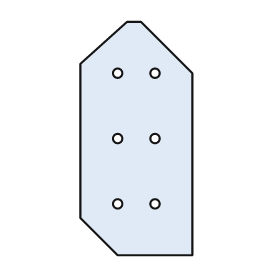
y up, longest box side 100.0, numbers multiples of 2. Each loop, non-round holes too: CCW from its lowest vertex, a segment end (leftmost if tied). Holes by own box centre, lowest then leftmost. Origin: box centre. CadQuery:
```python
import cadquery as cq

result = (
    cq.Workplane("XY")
    .moveTo(-8.0, -50.0)
    .lineTo(24.0, -50.0)
    .lineTo(24.0, 28.0)
    .lineTo(2.0, 50.0)
    .lineTo(-4.0, 50.0)
    .lineTo(-24.0, 32.0)
    .lineTo(-24.0, -34.0)
    .close()
    .moveTo(-8.0, -28.0)
    .circle(2.0)
    .moveTo(8.0, -28.0)
    .circle(2.0)
    .moveTo(-8.0, 0.0)
    .circle(2.0)
    .moveTo(8.0, 0.0)
    .circle(2.0)
    .moveTo(-8.0, 28.0)
    .circle(2.0)
    .moveTo(8.0, 28.0)
    .circle(2.0)
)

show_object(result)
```